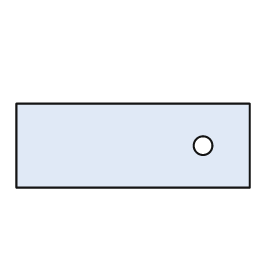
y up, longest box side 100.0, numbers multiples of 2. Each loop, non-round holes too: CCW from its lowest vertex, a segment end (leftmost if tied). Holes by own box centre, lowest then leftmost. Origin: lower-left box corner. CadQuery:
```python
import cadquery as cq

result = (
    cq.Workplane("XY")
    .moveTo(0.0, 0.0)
    .lineTo(100.0, 0.0)
    .lineTo(100.0, 36.0)
    .lineTo(0.0, 36.0)
    .close()
    .moveTo(80.0, 18.0)
    .circle(4.0)
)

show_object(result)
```